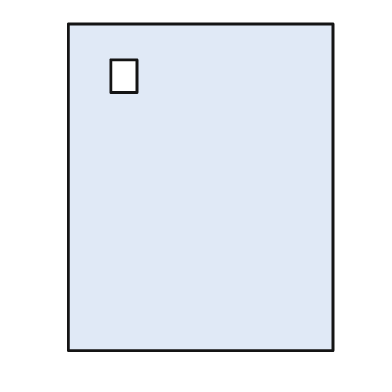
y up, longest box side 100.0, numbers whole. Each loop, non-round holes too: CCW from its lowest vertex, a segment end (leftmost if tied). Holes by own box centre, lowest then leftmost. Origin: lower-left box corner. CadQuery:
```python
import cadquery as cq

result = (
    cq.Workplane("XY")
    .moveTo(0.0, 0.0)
    .lineTo(81.0, 0.0)
    .lineTo(81.0, 100.0)
    .lineTo(0.0, 100.0)
    .close()
    .moveTo(13.0, 79.0)
    .lineTo(21.0, 79.0)
    .lineTo(21.0, 89.0)
    .lineTo(13.0, 89.0)
    .close()
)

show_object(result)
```